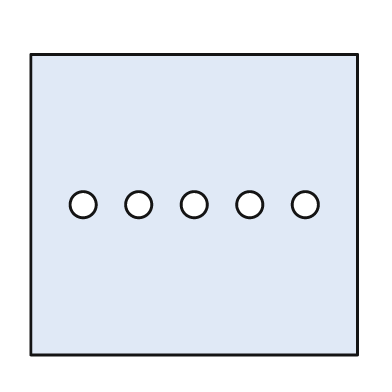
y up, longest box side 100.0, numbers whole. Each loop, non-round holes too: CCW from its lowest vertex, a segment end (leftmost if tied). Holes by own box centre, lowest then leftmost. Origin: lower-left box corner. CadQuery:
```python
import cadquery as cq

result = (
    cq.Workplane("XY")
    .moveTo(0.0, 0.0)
    .lineTo(100.0, 0.0)
    .lineTo(100.0, 92.0)
    .lineTo(0.0, 92.0)
    .close()
    .moveTo(16.0, 46.0)
    .circle(4.0)
    .moveTo(33.0, 46.0)
    .circle(4.0)
    .moveTo(50.0, 46.0)
    .circle(4.0)
    .moveTo(67.0, 46.0)
    .circle(4.0)
    .moveTo(84.0, 46.0)
    .circle(4.0)
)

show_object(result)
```